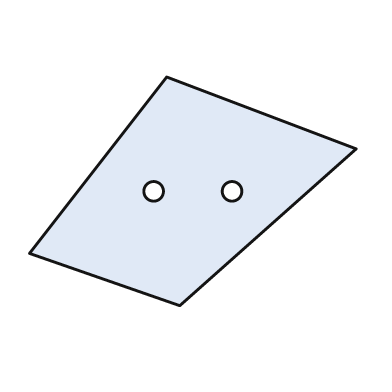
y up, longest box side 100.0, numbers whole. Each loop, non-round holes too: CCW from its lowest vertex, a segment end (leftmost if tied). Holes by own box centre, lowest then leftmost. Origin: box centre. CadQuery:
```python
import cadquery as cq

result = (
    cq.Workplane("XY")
    .moveTo(-4.0, -35.0)
    .lineTo(50.0, 13.0)
    .lineTo(-8.0, 35.0)
    .lineTo(-50.0, -19.0)
    .close()
    .moveTo(-12.0, 0.0)
    .circle(3.0)
    .moveTo(12.0, 0.0)
    .circle(3.0)
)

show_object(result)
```